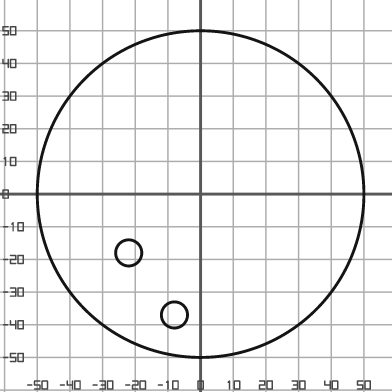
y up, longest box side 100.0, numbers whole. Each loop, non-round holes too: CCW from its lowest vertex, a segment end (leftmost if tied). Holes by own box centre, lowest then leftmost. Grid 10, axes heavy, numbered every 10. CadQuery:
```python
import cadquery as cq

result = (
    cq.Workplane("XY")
    .moveTo(0.0, 0.0)
    .circle(50.0)
    .moveTo(-8.0, -37.0)
    .circle(4.0)
    .moveTo(-22.0, -18.0)
    .circle(4.0)
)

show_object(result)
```